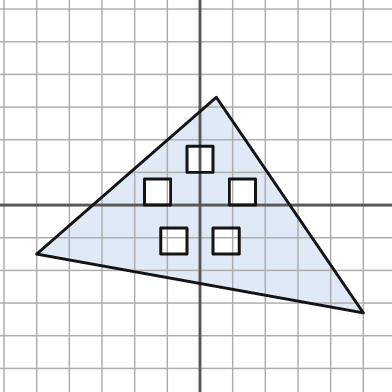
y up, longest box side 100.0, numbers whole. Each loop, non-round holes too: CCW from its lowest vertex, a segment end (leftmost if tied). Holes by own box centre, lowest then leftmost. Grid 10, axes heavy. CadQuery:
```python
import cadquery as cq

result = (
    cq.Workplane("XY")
    .moveTo(50.0, -33.0)
    .lineTo(5.0, 33.0)
    .lineTo(-50.0, -15.0)
    .close()
    .moveTo(-12.0, -15.0)
    .lineTo(-4.0, -15.0)
    .lineTo(-4.0, -7.0)
    .lineTo(-12.0, -7.0)
    .close()
    .moveTo(4.0, -15.0)
    .lineTo(12.0, -15.0)
    .lineTo(12.0, -7.0)
    .lineTo(4.0, -7.0)
    .close()
    .moveTo(-17.0, 0.0)
    .lineTo(-9.0, 0.0)
    .lineTo(-9.0, 8.0)
    .lineTo(-17.0, 8.0)
    .close()
    .moveTo(9.0, 0.0)
    .lineTo(17.0, 0.0)
    .lineTo(17.0, 8.0)
    .lineTo(9.0, 8.0)
    .close()
    .moveTo(-4.0, 10.0)
    .lineTo(4.0, 10.0)
    .lineTo(4.0, 18.0)
    .lineTo(-4.0, 18.0)
    .close()
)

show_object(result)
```